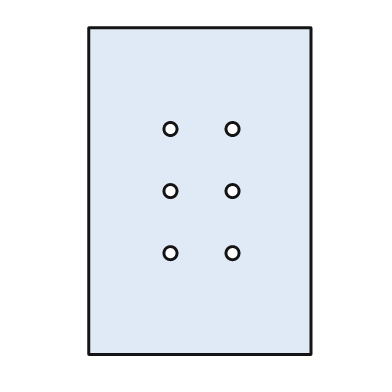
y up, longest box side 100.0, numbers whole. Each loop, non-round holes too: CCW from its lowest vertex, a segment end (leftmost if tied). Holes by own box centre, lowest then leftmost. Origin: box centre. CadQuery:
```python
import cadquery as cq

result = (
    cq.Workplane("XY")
    .moveTo(-34.0, -50.0)
    .lineTo(34.0, -50.0)
    .lineTo(34.0, 50.0)
    .lineTo(-34.0, 50.0)
    .close()
    .moveTo(-9.0, -19.0)
    .circle(2.0)
    .moveTo(10.0, -19.0)
    .circle(2.0)
    .moveTo(-9.0, 0.0)
    .circle(2.0)
    .moveTo(10.0, 0.0)
    .circle(2.0)
    .moveTo(-9.0, 19.0)
    .circle(2.0)
    .moveTo(10.0, 19.0)
    .circle(2.0)
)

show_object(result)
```